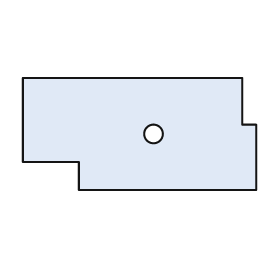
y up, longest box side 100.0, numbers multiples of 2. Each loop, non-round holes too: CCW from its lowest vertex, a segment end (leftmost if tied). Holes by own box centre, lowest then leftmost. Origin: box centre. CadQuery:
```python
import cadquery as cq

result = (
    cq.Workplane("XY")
    .moveTo(-26.0, -24.0)
    .lineTo(50.0, -24.0)
    .lineTo(50.0, 4.0)
    .lineTo(44.0, 4.0)
    .lineTo(44.0, 24.0)
    .lineTo(-50.0, 24.0)
    .lineTo(-50.0, -12.0)
    .lineTo(-26.0, -12.0)
    .close()
    .moveTo(6.0, 0.0)
    .circle(4.0)
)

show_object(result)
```